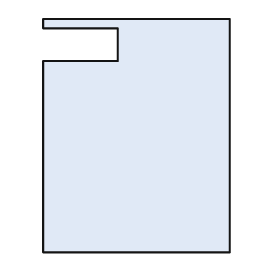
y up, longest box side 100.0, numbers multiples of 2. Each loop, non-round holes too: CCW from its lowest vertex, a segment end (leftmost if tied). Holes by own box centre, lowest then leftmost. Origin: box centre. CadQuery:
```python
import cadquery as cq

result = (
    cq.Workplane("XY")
    .moveTo(-40.0, -50.0)
    .lineTo(40.0, -50.0)
    .lineTo(40.0, 50.0)
    .lineTo(-40.0, 50.0)
    .lineTo(-40.0, 46.0)
    .lineTo(-8.0, 46.0)
    .lineTo(-8.0, 32.0)
    .lineTo(-40.0, 32.0)
    .close()
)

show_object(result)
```